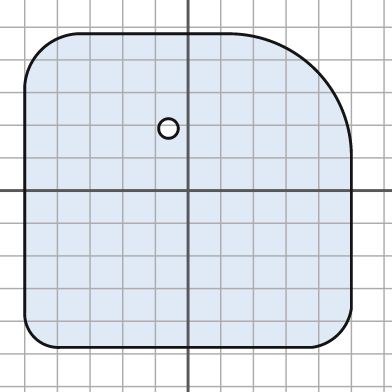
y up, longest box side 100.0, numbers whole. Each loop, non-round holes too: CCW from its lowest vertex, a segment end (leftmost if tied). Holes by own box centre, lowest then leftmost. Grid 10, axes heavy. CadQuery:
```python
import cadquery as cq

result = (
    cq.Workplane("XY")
    .moveTo(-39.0, -48.0)
    .lineTo(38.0, -48.0)
    .threePointArc((46.0, -44.0), (50.0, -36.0))
    .lineTo(50.0, 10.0)
    .threePointArc((39.0, 37.0), (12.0, 48.0))
    .lineTo(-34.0, 48.0)
    .threePointArc((-45.0, 43.0), (-50.0, 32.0))
    .lineTo(-50.0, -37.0)
    .threePointArc((-47.0, -45.0), (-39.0, -48.0))
    .close()
    .moveTo(-6.0, 19.0)
    .circle(3.0)
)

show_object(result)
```